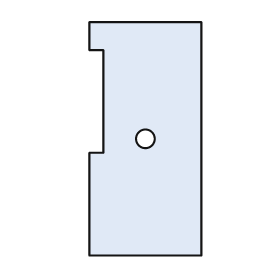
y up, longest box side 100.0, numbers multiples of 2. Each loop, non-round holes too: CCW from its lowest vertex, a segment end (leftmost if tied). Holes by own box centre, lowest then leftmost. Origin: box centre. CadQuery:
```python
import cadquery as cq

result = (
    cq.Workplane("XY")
    .moveTo(-24.0, -50.0)
    .lineTo(24.0, -50.0)
    .lineTo(24.0, 50.0)
    .lineTo(-24.0, 50.0)
    .lineTo(-24.0, 38.0)
    .lineTo(-18.0, 38.0)
    .lineTo(-18.0, -6.0)
    .lineTo(-24.0, -6.0)
    .close()
    .moveTo(0.0, 0.0)
    .circle(4.0)
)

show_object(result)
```